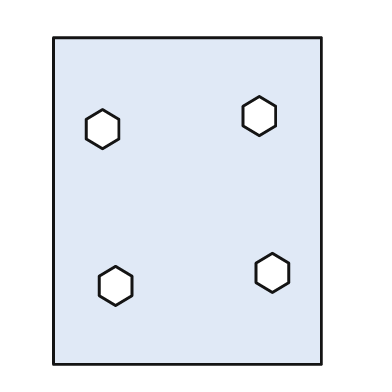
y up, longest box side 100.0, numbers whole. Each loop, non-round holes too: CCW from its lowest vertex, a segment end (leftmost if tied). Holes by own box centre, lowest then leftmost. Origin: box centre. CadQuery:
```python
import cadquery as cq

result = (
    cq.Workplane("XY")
    .moveTo(-41.0, -50.0)
    .lineTo(41.0, -50.0)
    .lineTo(41.0, 50.0)
    .lineTo(-41.0, 50.0)
    .close()
    .moveTo(-22.0, -32.0)
    .lineTo(-17.0, -29.0)
    .lineTo(-17.0, -23.0)
    .lineTo(-22.0, -20.0)
    .lineTo(-27.0, -23.0)
    .lineTo(-27.0, -29.0)
    .close()
    .moveTo(26.0, -28.0)
    .lineTo(31.0, -25.0)
    .lineTo(31.0, -19.0)
    .lineTo(26.0, -16.0)
    .lineTo(21.0, -19.0)
    .lineTo(21.0, -25.0)
    .close()
    .moveTo(-26.0, 16.0)
    .lineTo(-21.0, 19.0)
    .lineTo(-21.0, 25.0)
    .lineTo(-26.0, 28.0)
    .lineTo(-31.0, 25.0)
    .lineTo(-31.0, 19.0)
    .close()
    .moveTo(22.0, 20.0)
    .lineTo(27.0, 23.0)
    .lineTo(27.0, 29.0)
    .lineTo(22.0, 32.0)
    .lineTo(17.0, 29.0)
    .lineTo(17.0, 23.0)
    .close()
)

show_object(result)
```